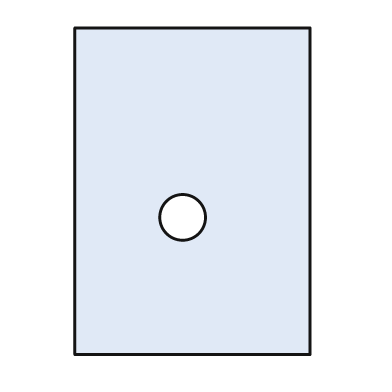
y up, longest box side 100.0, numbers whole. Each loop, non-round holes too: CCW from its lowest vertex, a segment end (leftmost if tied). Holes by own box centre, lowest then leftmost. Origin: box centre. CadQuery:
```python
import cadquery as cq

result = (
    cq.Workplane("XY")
    .moveTo(-36.0, -50.0)
    .lineTo(36.0, -50.0)
    .lineTo(36.0, 50.0)
    .lineTo(-36.0, 50.0)
    .close()
    .moveTo(-3.0, -8.0)
    .circle(7.0)
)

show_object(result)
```